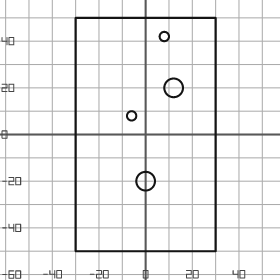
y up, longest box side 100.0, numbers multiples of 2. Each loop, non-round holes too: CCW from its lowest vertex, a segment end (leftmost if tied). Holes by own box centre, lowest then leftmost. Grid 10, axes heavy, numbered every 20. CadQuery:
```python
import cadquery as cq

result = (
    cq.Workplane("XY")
    .moveTo(-30.0, -50.0)
    .lineTo(30.0, -50.0)
    .lineTo(30.0, 50.0)
    .lineTo(-30.0, 50.0)
    .close()
    .moveTo(0.0, -20.0)
    .circle(4.0)
    .moveTo(-6.0, 8.0)
    .circle(2.0)
    .moveTo(12.0, 20.0)
    .circle(4.0)
    .moveTo(8.0, 42.0)
    .circle(2.0)
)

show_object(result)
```